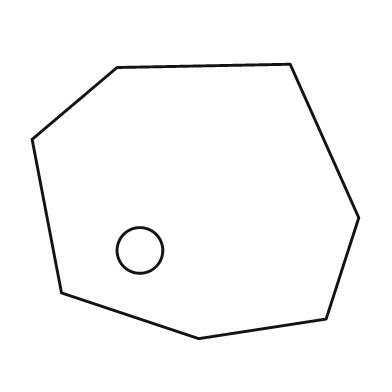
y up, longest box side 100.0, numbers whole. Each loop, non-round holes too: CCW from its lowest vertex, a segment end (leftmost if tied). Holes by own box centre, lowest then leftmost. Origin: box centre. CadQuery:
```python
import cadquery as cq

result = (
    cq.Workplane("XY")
    .moveTo(1.0, -42.0)
    .lineTo(40.0, -36.0)
    .lineTo(50.0, -5.0)
    .lineTo(29.0, 42.0)
    .lineTo(-24.0, 41.0)
    .lineTo(-50.0, 19.0)
    .lineTo(-41.0, -28.0)
    .close()
    .moveTo(-17.0, -15.0)
    .circle(7.0)
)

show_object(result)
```